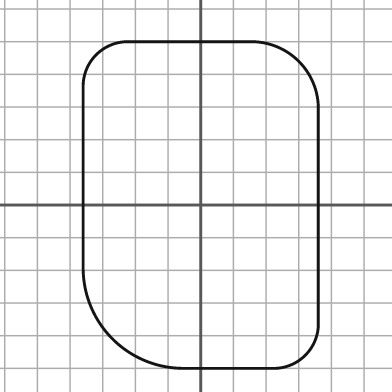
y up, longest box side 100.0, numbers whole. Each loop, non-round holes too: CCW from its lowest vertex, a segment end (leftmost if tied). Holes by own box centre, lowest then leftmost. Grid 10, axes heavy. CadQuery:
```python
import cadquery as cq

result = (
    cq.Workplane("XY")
    .moveTo(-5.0, -50.0)
    .lineTo(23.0, -50.0)
    .threePointArc((32.0, -46.0), (36.0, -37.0))
    .lineTo(36.0, 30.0)
    .threePointArc((30.0, 44.0), (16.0, 50.0))
    .lineTo(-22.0, 50.0)
    .threePointArc((-32.0, 46.0), (-36.0, 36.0))
    .lineTo(-36.0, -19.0)
    .threePointArc((-27.0, -41.0), (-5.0, -50.0))
    .close()
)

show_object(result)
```